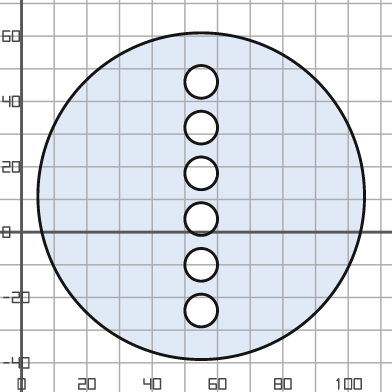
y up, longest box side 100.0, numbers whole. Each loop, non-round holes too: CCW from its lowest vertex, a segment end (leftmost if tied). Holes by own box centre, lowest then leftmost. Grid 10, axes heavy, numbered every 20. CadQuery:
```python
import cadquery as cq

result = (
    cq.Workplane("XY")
    .moveTo(55.0, 11.0)
    .circle(50.0)
    .moveTo(55.0, -24.0)
    .circle(5.0)
    .moveTo(55.0, -10.0)
    .circle(5.0)
    .moveTo(55.0, 4.0)
    .circle(5.0)
    .moveTo(55.0, 18.0)
    .circle(5.0)
    .moveTo(55.0, 32.0)
    .circle(5.0)
    .moveTo(55.0, 46.0)
    .circle(5.0)
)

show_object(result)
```